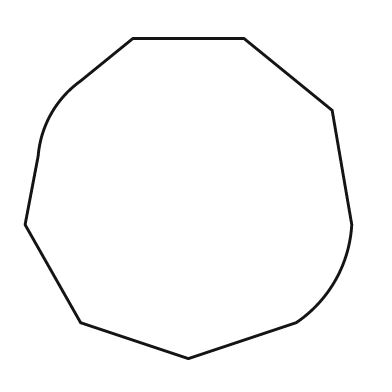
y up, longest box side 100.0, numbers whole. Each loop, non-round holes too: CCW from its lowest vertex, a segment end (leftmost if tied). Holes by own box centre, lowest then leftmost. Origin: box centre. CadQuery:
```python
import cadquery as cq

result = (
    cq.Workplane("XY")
    .moveTo(0.0, -49.0)
    .lineTo(33.0, -38.0)
    .threePointArc((45.0, -25.0), (50.0, -8.0))
    .lineTo(44.0, 27.0)
    .lineTo(17.0, 49.0)
    .lineTo(-17.0, 49.0)
    .lineTo(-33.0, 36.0)
    .threePointArc((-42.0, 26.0), (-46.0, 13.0))
    .lineTo(-50.0, -8.0)
    .lineTo(-33.0, -38.0)
    .close()
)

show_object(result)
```